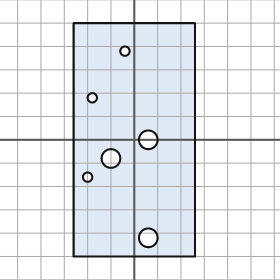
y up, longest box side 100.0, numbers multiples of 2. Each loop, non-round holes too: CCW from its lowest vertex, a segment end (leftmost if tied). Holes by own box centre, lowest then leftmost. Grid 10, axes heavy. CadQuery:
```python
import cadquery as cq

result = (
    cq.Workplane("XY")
    .moveTo(-26.0, -50.0)
    .lineTo(26.0, -50.0)
    .lineTo(26.0, 50.0)
    .lineTo(-26.0, 50.0)
    .close()
    .moveTo(6.0, -42.0)
    .circle(4.0)
    .moveTo(-20.0, -16.0)
    .circle(2.0)
    .moveTo(-10.0, -8.0)
    .circle(4.0)
    .moveTo(6.0, 0.0)
    .circle(4.0)
    .moveTo(-18.0, 18.0)
    .circle(2.0)
    .moveTo(-4.0, 38.0)
    .circle(2.0)
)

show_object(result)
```